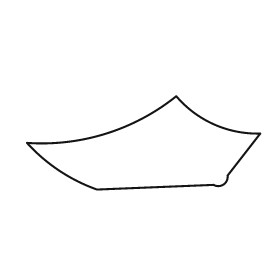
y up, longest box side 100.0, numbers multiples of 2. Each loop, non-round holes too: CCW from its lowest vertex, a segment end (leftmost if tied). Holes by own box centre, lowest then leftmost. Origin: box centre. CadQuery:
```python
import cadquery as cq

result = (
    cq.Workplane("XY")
    .moveTo(-20.0, -20.0)
    .lineTo(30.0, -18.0)
    .threePointArc((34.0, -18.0), (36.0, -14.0))
    .lineTo(50.0, 4.0)
    .threePointArc((30.0, 8.0), (14.0, 20.0))
    .threePointArc((-16.0, 4.0), (-50.0, 0.0))
    .threePointArc((-36.0, -12.0), (-20.0, -20.0))
    .close()
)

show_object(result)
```